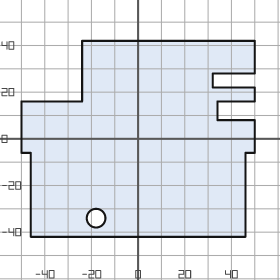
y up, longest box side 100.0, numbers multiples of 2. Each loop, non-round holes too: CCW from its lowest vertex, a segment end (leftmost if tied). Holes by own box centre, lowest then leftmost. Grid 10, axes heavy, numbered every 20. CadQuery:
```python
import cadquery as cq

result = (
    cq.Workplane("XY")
    .moveTo(-46.0, -42.0)
    .lineTo(46.0, -42.0)
    .lineTo(46.0, -6.0)
    .lineTo(50.0, -6.0)
    .lineTo(50.0, 8.0)
    .lineTo(34.0, 8.0)
    .lineTo(34.0, 16.0)
    .lineTo(50.0, 16.0)
    .lineTo(50.0, 22.0)
    .lineTo(32.0, 22.0)
    .lineTo(32.0, 28.0)
    .lineTo(50.0, 28.0)
    .lineTo(50.0, 42.0)
    .lineTo(-24.0, 42.0)
    .lineTo(-24.0, 16.0)
    .lineTo(-50.0, 16.0)
    .lineTo(-50.0, -6.0)
    .lineTo(-46.0, -6.0)
    .close()
    .moveTo(-18.0, -34.0)
    .circle(4.0)
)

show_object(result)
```